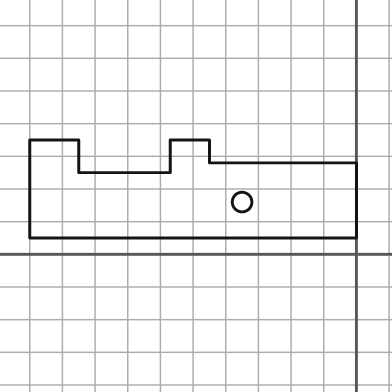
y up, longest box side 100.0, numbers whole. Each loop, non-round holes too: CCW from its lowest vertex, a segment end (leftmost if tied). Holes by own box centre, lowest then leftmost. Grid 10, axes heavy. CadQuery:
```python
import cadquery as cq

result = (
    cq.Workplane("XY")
    .moveTo(-100.0, 5.0)
    .lineTo(0.0, 5.0)
    .lineTo(0.0, 28.0)
    .lineTo(-45.0, 28.0)
    .lineTo(-45.0, 35.0)
    .lineTo(-57.0, 35.0)
    .lineTo(-57.0, 25.0)
    .lineTo(-85.0, 25.0)
    .lineTo(-85.0, 35.0)
    .lineTo(-100.0, 35.0)
    .close()
    .moveTo(-35.0, 16.0)
    .circle(3.0)
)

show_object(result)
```